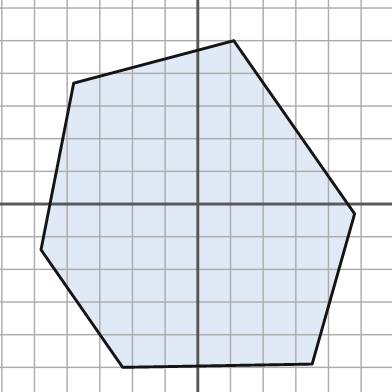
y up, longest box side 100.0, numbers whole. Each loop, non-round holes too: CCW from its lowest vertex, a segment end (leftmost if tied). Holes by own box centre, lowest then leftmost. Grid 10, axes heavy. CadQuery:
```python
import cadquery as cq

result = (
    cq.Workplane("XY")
    .moveTo(-23.0, -50.0)
    .lineTo(35.0, -49.0)
    .lineTo(48.0, -3.0)
    .lineTo(11.0, 50.0)
    .lineTo(-38.0, 37.0)
    .lineTo(-48.0, -14.0)
    .close()
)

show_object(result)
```